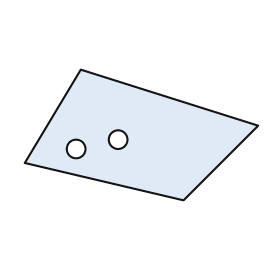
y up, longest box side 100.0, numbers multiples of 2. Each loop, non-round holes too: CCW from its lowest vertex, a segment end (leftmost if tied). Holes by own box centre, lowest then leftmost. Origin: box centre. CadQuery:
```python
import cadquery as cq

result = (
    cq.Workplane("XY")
    .moveTo(18.0, -28.0)
    .lineTo(50.0, 4.0)
    .lineTo(-26.0, 28.0)
    .lineTo(-50.0, -12.0)
    .close()
    .moveTo(-28.0, -6.0)
    .circle(4.0)
    .moveTo(-10.0, -2.0)
    .circle(4.0)
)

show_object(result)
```